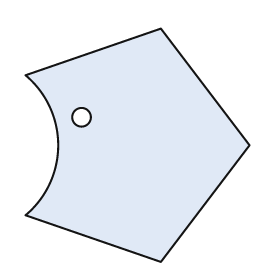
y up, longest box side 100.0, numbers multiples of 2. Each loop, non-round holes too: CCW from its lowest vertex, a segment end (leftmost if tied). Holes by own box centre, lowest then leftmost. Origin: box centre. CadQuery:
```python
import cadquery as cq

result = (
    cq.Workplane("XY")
    .moveTo(10.0, -50.0)
    .lineTo(48.0, 0.0)
    .lineTo(10.0, 50.0)
    .lineTo(-48.0, 30.0)
    .threePointArc((-34.0, 0.0), (-48.0, -30.0))
    .close()
    .moveTo(-24.0, 12.0)
    .circle(4.0)
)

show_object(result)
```